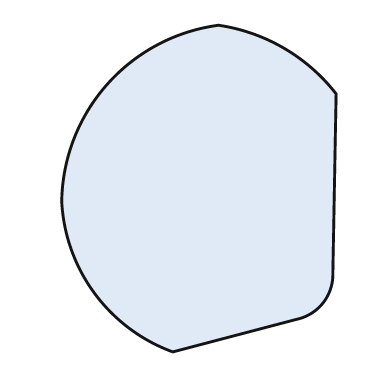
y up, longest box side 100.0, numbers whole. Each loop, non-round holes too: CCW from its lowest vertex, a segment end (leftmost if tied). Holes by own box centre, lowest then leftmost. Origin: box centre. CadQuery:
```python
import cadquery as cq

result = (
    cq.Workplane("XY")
    .moveTo(-8.0, -50.0)
    .lineTo(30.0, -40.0)
    .threePointArc((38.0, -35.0), (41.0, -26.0))
    .lineTo(42.0, 29.0)
    .threePointArc((26.0, 43.0), (6.0, 50.0))
    .threePointArc((-28.0, 32.0), (-42.0, -4.0))
    .threePointArc((-32.0, -32.0), (-8.0, -50.0))
    .close()
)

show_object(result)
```